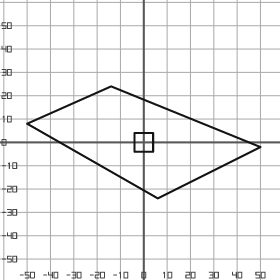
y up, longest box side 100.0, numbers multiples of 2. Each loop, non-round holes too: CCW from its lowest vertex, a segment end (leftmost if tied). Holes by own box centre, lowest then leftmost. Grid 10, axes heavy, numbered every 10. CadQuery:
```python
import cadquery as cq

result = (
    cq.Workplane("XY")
    .moveTo(6.0, -24.0)
    .lineTo(50.0, -2.0)
    .lineTo(-14.0, 24.0)
    .lineTo(-50.0, 8.0)
    .close()
    .moveTo(-4.0, -4.0)
    .lineTo(4.0, -4.0)
    .lineTo(4.0, 4.0)
    .lineTo(-4.0, 4.0)
    .close()
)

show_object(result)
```